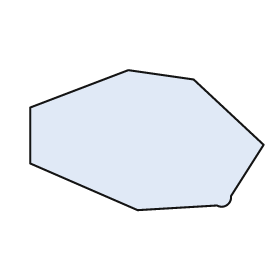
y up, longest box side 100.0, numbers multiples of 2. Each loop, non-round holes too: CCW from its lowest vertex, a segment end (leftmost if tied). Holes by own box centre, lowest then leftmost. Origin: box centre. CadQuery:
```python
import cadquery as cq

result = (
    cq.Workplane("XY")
    .moveTo(-4.0, -30.0)
    .lineTo(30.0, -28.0)
    .threePointArc((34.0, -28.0), (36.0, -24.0))
    .lineTo(50.0, -2.0)
    .lineTo(20.0, 26.0)
    .lineTo(-8.0, 30.0)
    .lineTo(-50.0, 14.0)
    .lineTo(-50.0, -10.0)
    .close()
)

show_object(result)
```